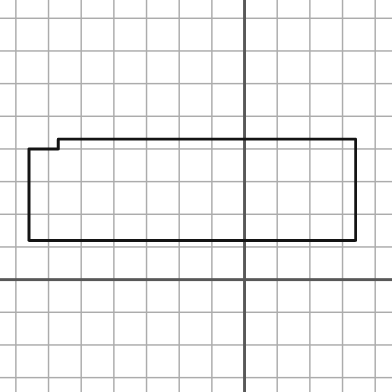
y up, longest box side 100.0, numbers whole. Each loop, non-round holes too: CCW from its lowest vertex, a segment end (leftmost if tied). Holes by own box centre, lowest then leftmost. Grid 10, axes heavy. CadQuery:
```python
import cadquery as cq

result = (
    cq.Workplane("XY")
    .moveTo(-66.0, 12.0)
    .lineTo(34.0, 12.0)
    .lineTo(34.0, 43.0)
    .lineTo(-57.0, 43.0)
    .lineTo(-57.0, 40.0)
    .lineTo(-66.0, 40.0)
    .close()
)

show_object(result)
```